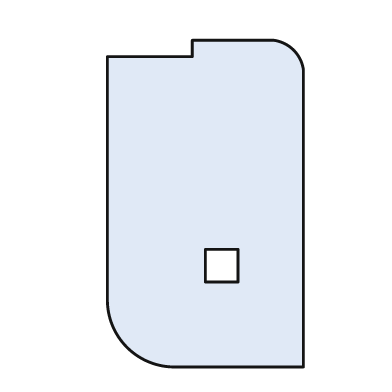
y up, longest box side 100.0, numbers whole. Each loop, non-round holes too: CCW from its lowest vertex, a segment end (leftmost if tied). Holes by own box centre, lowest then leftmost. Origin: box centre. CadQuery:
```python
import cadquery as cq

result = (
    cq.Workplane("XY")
    .moveTo(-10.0, -50.0)
    .lineTo(30.0, -50.0)
    .lineTo(30.0, 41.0)
    .threePointArc((27.0, 47.0), (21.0, 50.0))
    .lineTo(-4.0, 50.0)
    .lineTo(-4.0, 45.0)
    .lineTo(-30.0, 45.0)
    .lineTo(-30.0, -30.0)
    .threePointArc((-24.0, -44.0), (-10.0, -50.0))
    .close()
    .moveTo(0.0, -24.0)
    .lineTo(10.0, -24.0)
    .lineTo(10.0, -14.0)
    .lineTo(0.0, -14.0)
    .close()
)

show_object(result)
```